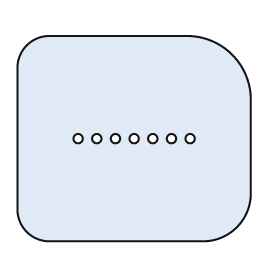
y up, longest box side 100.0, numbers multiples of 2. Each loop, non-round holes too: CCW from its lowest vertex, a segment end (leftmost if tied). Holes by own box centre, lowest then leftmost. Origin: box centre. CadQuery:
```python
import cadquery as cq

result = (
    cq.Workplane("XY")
    .moveTo(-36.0, -44.0)
    .lineTo(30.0, -44.0)
    .threePointArc((44.0, -38.0), (50.0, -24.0))
    .lineTo(50.0, 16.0)
    .threePointArc((42.0, 36.0), (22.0, 44.0))
    .lineTo(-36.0, 44.0)
    .threePointArc((-46.0, 40.0), (-50.0, 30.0))
    .lineTo(-50.0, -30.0)
    .threePointArc((-46.0, -40.0), (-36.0, -44.0))
    .close()
    .moveTo(-24.0, 0.0)
    .circle(2.0)
    .moveTo(-16.0, 0.0)
    .circle(2.0)
    .moveTo(-8.0, 0.0)
    .circle(2.0)
    .moveTo(0.0, 0.0)
    .circle(2.0)
    .moveTo(8.0, 0.0)
    .circle(2.0)
    .moveTo(16.0, 0.0)
    .circle(2.0)
    .moveTo(24.0, 0.0)
    .circle(2.0)
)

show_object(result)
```